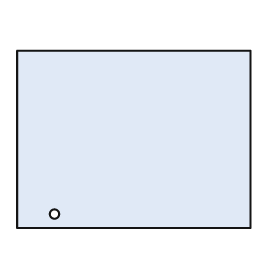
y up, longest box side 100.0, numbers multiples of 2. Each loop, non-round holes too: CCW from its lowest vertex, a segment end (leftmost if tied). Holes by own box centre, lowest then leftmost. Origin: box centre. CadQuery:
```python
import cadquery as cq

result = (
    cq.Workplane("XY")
    .moveTo(-50.0, -38.0)
    .lineTo(50.0, -38.0)
    .lineTo(50.0, 38.0)
    .lineTo(-50.0, 38.0)
    .close()
    .moveTo(-34.0, -32.0)
    .circle(2.0)
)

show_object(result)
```